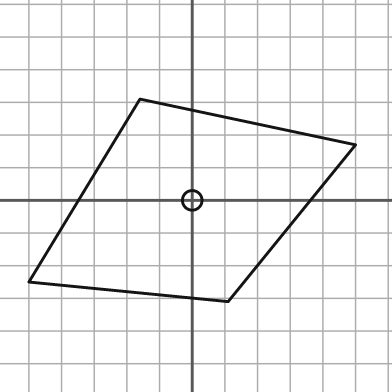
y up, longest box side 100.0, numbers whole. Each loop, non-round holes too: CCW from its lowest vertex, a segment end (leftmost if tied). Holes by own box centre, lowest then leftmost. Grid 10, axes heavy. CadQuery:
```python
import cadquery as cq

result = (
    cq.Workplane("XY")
    .moveTo(11.0, -31.0)
    .lineTo(50.0, 17.0)
    .lineTo(-16.0, 31.0)
    .lineTo(-50.0, -25.0)
    .close()
    .moveTo(0.0, 0.0)
    .circle(3.0)
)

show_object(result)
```